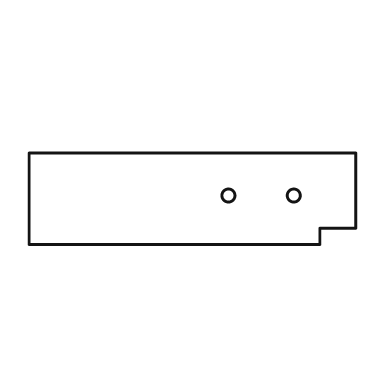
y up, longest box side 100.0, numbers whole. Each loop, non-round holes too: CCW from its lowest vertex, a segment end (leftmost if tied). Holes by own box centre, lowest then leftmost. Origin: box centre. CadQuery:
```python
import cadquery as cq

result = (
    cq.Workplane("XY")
    .moveTo(-50.0, -14.0)
    .lineTo(39.0, -14.0)
    .lineTo(39.0, -9.0)
    .lineTo(50.0, -9.0)
    .lineTo(50.0, 14.0)
    .lineTo(-50.0, 14.0)
    .close()
    .moveTo(11.0, 1.0)
    .circle(2.0)
    .moveTo(31.0, 1.0)
    .circle(2.0)
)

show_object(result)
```